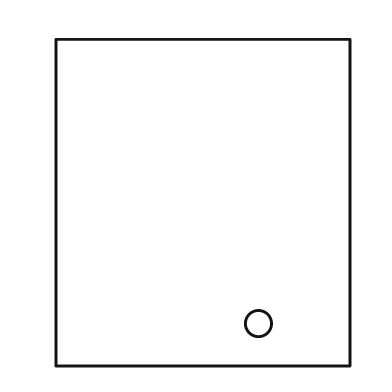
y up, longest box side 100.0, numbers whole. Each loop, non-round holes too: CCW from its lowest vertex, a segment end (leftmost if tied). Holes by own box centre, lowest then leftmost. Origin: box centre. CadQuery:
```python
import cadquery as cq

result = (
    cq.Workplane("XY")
    .moveTo(-45.0, -50.0)
    .lineTo(45.0, -50.0)
    .lineTo(45.0, 50.0)
    .lineTo(-45.0, 50.0)
    .close()
    .moveTo(17.0, -37.0)
    .circle(4.0)
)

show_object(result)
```